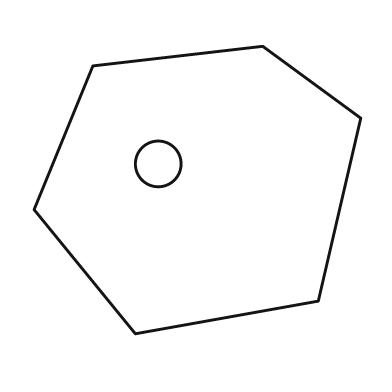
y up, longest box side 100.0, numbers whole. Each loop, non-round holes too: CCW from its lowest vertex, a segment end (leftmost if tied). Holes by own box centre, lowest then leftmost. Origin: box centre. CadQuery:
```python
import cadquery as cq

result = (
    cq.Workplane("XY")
    .moveTo(-19.0, -44.0)
    .lineTo(37.0, -34.0)
    .lineTo(50.0, 22.0)
    .lineTo(20.0, 44.0)
    .lineTo(-32.0, 38.0)
    .lineTo(-50.0, -6.0)
    .close()
    .moveTo(-12.0, 8.0)
    .circle(7.0)
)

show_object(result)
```